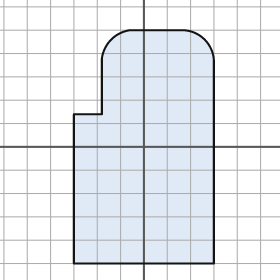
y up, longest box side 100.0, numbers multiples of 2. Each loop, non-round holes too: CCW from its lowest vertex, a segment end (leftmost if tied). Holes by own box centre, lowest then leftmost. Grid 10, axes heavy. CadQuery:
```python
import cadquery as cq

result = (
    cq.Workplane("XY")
    .moveTo(-30.0, -50.0)
    .lineTo(30.0, -50.0)
    .lineTo(30.0, 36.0)
    .threePointArc((26.0, 46.0), (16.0, 50.0))
    .lineTo(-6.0, 50.0)
    .threePointArc((-14.0, 46.0), (-18.0, 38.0))
    .lineTo(-18.0, 14.0)
    .lineTo(-30.0, 14.0)
    .close()
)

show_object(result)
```